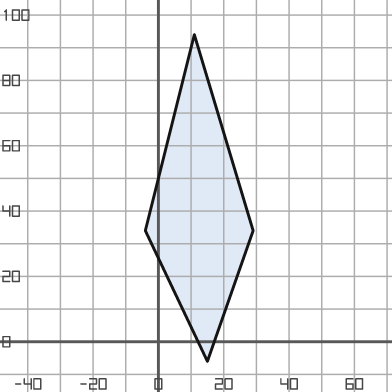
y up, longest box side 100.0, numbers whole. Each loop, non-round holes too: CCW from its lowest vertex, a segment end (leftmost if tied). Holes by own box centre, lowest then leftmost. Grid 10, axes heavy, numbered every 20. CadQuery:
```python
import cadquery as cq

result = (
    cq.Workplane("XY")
    .moveTo(15.0, -6.0)
    .lineTo(29.0, 34.0)
    .lineTo(11.0, 94.0)
    .lineTo(-4.0, 34.0)
    .close()
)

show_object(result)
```